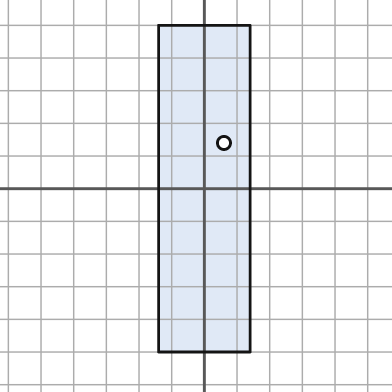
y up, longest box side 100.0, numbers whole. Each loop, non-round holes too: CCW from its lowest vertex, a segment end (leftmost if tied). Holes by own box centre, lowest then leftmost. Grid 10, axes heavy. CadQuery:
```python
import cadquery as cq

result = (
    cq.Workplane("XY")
    .moveTo(-14.0, -50.0)
    .lineTo(14.0, -50.0)
    .lineTo(14.0, 50.0)
    .lineTo(-14.0, 50.0)
    .close()
    .moveTo(6.0, 14.0)
    .circle(2.0)
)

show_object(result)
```